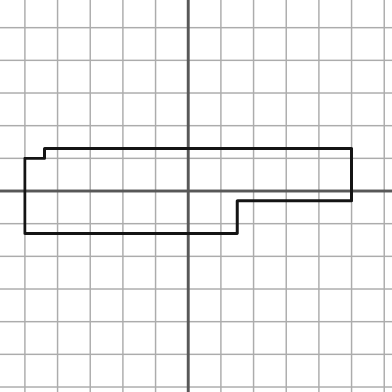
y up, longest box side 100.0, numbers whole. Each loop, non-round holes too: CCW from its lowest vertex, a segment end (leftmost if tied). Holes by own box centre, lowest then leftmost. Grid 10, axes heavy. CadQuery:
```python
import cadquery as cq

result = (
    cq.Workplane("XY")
    .moveTo(-50.0, -13.0)
    .lineTo(15.0, -13.0)
    .lineTo(15.0, -3.0)
    .lineTo(50.0, -3.0)
    .lineTo(50.0, 13.0)
    .lineTo(-44.0, 13.0)
    .lineTo(-44.0, 10.0)
    .lineTo(-50.0, 10.0)
    .close()
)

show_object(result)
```